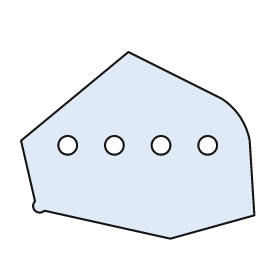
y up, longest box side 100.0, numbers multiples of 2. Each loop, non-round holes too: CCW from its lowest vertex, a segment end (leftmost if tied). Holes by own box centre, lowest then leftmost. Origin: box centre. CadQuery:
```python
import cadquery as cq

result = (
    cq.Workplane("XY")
    .moveTo(14.0, -40.0)
    .lineTo(50.0, -30.0)
    .lineTo(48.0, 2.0)
    .threePointArc((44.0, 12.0), (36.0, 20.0))
    .lineTo(-4.0, 40.0)
    .lineTo(-50.0, 2.0)
    .lineTo(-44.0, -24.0)
    .threePointArc((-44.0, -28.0), (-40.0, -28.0))
    .close()
    .moveTo(-30.0, 0.0)
    .circle(4.0)
    .moveTo(-10.0, 0.0)
    .circle(4.0)
    .moveTo(10.0, 0.0)
    .circle(4.0)
    .moveTo(30.0, 0.0)
    .circle(4.0)
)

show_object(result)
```